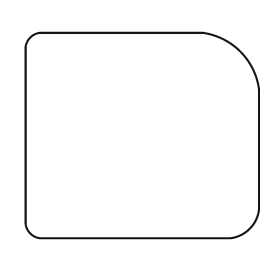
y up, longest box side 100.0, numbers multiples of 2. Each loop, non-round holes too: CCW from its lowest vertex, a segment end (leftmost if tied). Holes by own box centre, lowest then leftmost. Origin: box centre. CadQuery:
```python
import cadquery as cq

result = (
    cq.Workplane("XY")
    .moveTo(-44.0, -44.0)
    .lineTo(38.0, -44.0)
    .threePointArc((46.0, -40.0), (50.0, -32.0))
    .lineTo(50.0, 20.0)
    .threePointArc((42.0, 36.0), (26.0, 44.0))
    .lineTo(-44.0, 44.0)
    .threePointArc((-48.0, 42.0), (-50.0, 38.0))
    .lineTo(-50.0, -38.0)
    .threePointArc((-48.0, -42.0), (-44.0, -44.0))
    .close()
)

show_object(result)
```